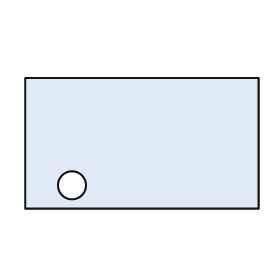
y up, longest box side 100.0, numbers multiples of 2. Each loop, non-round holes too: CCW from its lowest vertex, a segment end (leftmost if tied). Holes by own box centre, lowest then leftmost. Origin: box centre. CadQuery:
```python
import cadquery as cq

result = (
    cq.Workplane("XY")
    .moveTo(-50.0, -28.0)
    .lineTo(50.0, -28.0)
    .lineTo(50.0, 28.0)
    .lineTo(-50.0, 28.0)
    .close()
    .moveTo(-30.0, -18.0)
    .circle(6.0)
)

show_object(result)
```